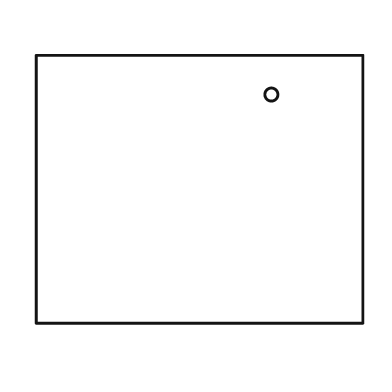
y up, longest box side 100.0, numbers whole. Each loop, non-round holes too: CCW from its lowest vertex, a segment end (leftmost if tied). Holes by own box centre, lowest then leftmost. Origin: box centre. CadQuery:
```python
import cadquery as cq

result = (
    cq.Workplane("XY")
    .moveTo(-50.0, -41.0)
    .lineTo(50.0, -41.0)
    .lineTo(50.0, 41.0)
    .lineTo(-50.0, 41.0)
    .close()
    .moveTo(22.0, 29.0)
    .circle(2.0)
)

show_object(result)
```